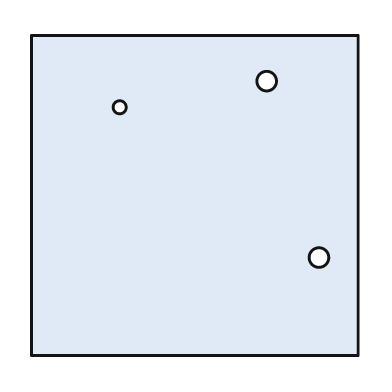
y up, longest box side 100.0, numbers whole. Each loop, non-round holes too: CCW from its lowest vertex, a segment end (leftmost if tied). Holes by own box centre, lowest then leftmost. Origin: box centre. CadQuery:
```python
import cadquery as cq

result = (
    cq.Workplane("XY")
    .moveTo(-50.0, -49.0)
    .lineTo(50.0, -49.0)
    .lineTo(50.0, 49.0)
    .lineTo(-50.0, 49.0)
    .close()
    .moveTo(38.0, -19.0)
    .circle(3.0)
    .moveTo(-23.0, 27.0)
    .circle(2.0)
    .moveTo(22.0, 35.0)
    .circle(3.0)
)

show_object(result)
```